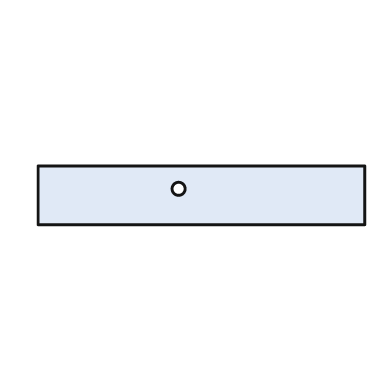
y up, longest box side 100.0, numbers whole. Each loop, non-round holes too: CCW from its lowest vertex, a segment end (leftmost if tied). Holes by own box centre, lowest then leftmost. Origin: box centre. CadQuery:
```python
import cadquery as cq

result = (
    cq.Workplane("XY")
    .moveTo(-50.0, -9.0)
    .lineTo(50.0, -9.0)
    .lineTo(50.0, 9.0)
    .lineTo(-50.0, 9.0)
    .close()
    .moveTo(-7.0, 2.0)
    .circle(2.0)
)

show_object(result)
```